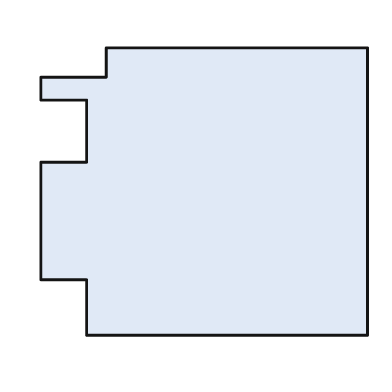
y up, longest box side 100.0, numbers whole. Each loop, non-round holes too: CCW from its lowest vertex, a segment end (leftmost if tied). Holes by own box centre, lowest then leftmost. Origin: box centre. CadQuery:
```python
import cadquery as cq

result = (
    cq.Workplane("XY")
    .moveTo(-36.0, -44.0)
    .lineTo(50.0, -44.0)
    .lineTo(50.0, 44.0)
    .lineTo(-30.0, 44.0)
    .lineTo(-30.0, 35.0)
    .lineTo(-50.0, 35.0)
    .lineTo(-50.0, 28.0)
    .lineTo(-36.0, 28.0)
    .lineTo(-36.0, 9.0)
    .lineTo(-50.0, 9.0)
    .lineTo(-50.0, -27.0)
    .lineTo(-36.0, -27.0)
    .close()
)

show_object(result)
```